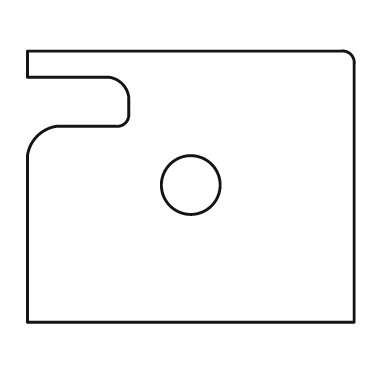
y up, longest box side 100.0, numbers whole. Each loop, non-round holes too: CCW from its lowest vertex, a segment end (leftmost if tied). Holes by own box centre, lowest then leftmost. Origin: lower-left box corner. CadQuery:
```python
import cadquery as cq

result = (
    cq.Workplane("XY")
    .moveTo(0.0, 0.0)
    .lineTo(100.0, 0.0)
    .lineTo(100.0, 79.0)
    .threePointArc((99.0, 82.0), (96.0, 83.0))
    .lineTo(0.0, 83.0)
    .lineTo(0.0, 75.0)
    .lineTo(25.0, 75.0)
    .threePointArc((29.0, 73.0), (31.0, 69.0))
    .lineTo(31.0, 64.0)
    .threePointArc((30.0, 61.0), (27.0, 60.0))
    .lineTo(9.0, 60.0)
    .threePointArc((3.0, 57.0), (0.0, 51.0))
    .close()
    .moveTo(50.0, 42.0)
    .circle(9.0)
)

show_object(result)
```